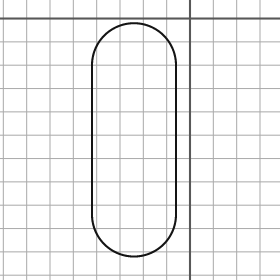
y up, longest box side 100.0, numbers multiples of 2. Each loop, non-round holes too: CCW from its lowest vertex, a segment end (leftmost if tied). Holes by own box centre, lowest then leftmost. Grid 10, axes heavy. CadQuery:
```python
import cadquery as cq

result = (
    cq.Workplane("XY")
    .moveTo(-42.0, -84.0)
    .threePointArc((-24.0, -102.0), (-6.0, -84.0))
    .lineTo(-6.0, -20.0)
    .threePointArc((-24.0, -2.0), (-42.0, -20.0))
    .close()
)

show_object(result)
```